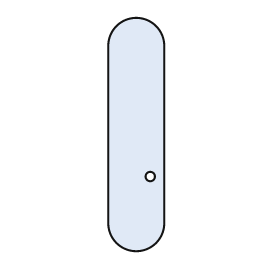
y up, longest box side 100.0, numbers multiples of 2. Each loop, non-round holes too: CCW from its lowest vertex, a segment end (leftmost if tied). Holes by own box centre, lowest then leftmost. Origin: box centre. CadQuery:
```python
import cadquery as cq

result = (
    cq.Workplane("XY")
    .moveTo(-12.0, -38.0)
    .threePointArc((0.0, -50.0), (12.0, -38.0))
    .lineTo(12.0, 38.0)
    .threePointArc((0.0, 50.0), (-12.0, 38.0))
    .close()
    .moveTo(6.0, -18.0)
    .circle(2.0)
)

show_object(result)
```